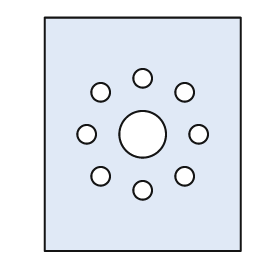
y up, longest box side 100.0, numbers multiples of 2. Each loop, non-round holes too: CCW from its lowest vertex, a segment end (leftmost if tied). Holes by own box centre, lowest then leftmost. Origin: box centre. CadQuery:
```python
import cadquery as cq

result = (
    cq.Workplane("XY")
    .moveTo(-42.0, -50.0)
    .lineTo(42.0, -50.0)
    .lineTo(42.0, 50.0)
    .lineTo(-42.0, 50.0)
    .close()
    .moveTo(0.0, -24.0)
    .circle(4.0)
    .moveTo(-18.0, -18.0)
    .circle(4.0)
    .moveTo(18.0, -18.0)
    .circle(4.0)
    .moveTo(-24.0, 0.0)
    .circle(4.0)
    .moveTo(0.0, 0.0)
    .circle(10.0)
    .moveTo(24.0, 0.0)
    .circle(4.0)
    .moveTo(-18.0, 18.0)
    .circle(4.0)
    .moveTo(18.0, 18.0)
    .circle(4.0)
    .moveTo(0.0, 24.0)
    .circle(4.0)
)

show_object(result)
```